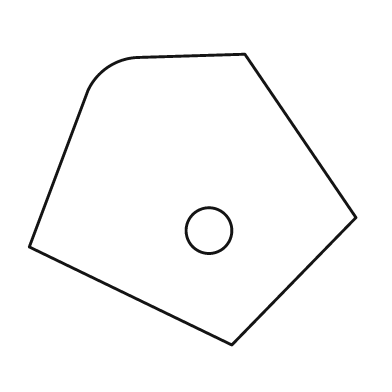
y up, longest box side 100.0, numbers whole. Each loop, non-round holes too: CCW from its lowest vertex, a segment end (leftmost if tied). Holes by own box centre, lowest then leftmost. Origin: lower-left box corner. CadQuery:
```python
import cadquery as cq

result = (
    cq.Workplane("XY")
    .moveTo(62.0, 0.0)
    .lineTo(100.0, 39.0)
    .lineTo(66.0, 89.0)
    .lineTo(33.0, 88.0)
    .threePointArc((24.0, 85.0), (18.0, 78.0))
    .lineTo(0.0, 30.0)
    .close()
    .moveTo(55.0, 35.0)
    .circle(7.0)
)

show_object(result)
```